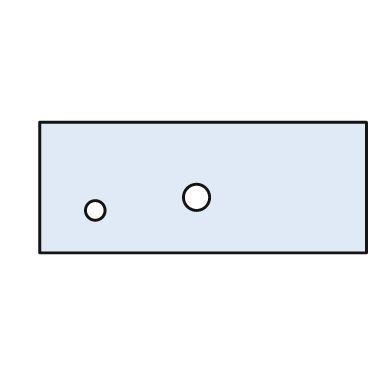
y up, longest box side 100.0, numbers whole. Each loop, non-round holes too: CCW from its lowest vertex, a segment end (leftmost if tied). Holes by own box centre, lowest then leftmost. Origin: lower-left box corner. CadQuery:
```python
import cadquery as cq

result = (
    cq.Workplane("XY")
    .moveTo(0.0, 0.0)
    .lineTo(100.0, 0.0)
    .lineTo(100.0, 40.0)
    .lineTo(0.0, 40.0)
    .close()
    .moveTo(17.0, 13.0)
    .circle(3.0)
    .moveTo(48.0, 17.0)
    .circle(4.0)
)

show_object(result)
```